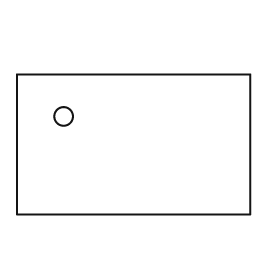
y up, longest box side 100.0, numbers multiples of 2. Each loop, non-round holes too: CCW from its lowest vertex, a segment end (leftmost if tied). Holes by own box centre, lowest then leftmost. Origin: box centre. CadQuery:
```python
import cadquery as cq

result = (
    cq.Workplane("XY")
    .moveTo(-50.0, -30.0)
    .lineTo(50.0, -30.0)
    .lineTo(50.0, 30.0)
    .lineTo(-50.0, 30.0)
    .close()
    .moveTo(-30.0, 12.0)
    .circle(4.0)
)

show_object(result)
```